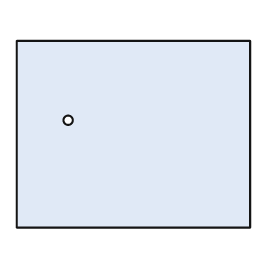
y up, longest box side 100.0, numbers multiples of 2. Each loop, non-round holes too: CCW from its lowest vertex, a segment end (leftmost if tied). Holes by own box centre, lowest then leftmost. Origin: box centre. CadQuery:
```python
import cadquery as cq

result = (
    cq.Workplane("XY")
    .moveTo(-50.0, -40.0)
    .lineTo(50.0, -40.0)
    .lineTo(50.0, 40.0)
    .lineTo(-50.0, 40.0)
    .close()
    .moveTo(-28.0, 6.0)
    .circle(2.0)
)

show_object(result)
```